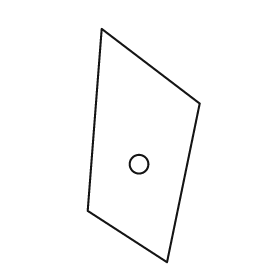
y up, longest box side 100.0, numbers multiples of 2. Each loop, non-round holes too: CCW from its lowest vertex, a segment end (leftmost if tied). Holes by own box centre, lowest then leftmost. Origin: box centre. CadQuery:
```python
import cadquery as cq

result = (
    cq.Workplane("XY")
    .moveTo(10.0, -50.0)
    .lineTo(24.0, 18.0)
    .lineTo(-18.0, 50.0)
    .lineTo(-24.0, -28.0)
    .close()
    .moveTo(-2.0, -8.0)
    .circle(4.0)
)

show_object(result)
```